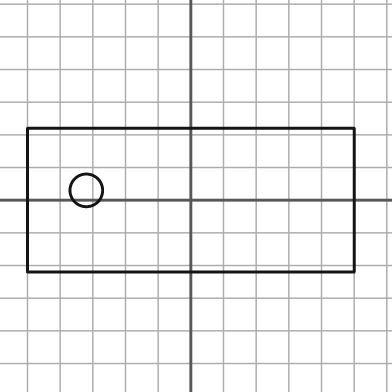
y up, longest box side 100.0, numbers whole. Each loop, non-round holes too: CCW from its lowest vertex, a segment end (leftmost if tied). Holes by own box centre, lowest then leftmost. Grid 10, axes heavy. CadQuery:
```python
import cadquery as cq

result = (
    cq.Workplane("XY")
    .moveTo(-50.0, -22.0)
    .lineTo(50.0, -22.0)
    .lineTo(50.0, 22.0)
    .lineTo(-50.0, 22.0)
    .close()
    .moveTo(-32.0, 3.0)
    .circle(5.0)
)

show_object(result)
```